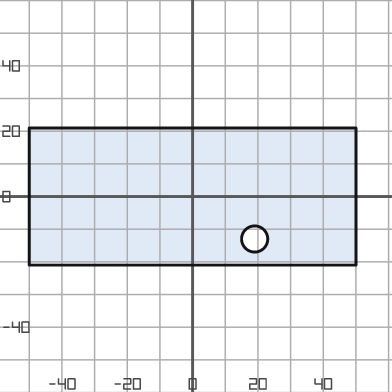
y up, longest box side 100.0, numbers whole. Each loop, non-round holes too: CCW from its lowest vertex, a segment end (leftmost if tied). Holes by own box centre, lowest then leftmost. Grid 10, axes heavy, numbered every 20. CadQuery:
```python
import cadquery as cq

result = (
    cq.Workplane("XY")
    .moveTo(-50.0, -21.0)
    .lineTo(50.0, -21.0)
    .lineTo(50.0, 21.0)
    .lineTo(-50.0, 21.0)
    .close()
    .moveTo(19.0, -13.0)
    .circle(4.0)
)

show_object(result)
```